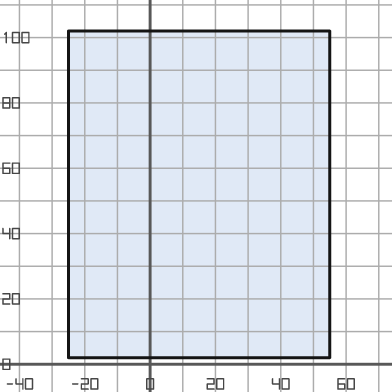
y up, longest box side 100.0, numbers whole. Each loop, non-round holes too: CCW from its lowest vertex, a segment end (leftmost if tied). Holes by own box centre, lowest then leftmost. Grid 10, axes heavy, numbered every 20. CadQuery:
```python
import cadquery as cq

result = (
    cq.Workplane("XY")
    .moveTo(-25.0, 2.0)
    .lineTo(55.0, 2.0)
    .lineTo(55.0, 102.0)
    .lineTo(-25.0, 102.0)
    .close()
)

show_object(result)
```